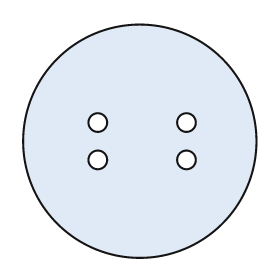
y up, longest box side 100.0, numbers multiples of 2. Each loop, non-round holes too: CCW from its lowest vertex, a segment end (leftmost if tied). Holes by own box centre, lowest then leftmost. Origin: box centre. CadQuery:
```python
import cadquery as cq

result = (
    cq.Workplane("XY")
    .moveTo(0.0, 0.0)
    .circle(50.0)
    .moveTo(-18.0, -8.0)
    .circle(4.0)
    .moveTo(20.0, -8.0)
    .circle(4.0)
    .moveTo(-18.0, 8.0)
    .circle(4.0)
    .moveTo(20.0, 8.0)
    .circle(4.0)
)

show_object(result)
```